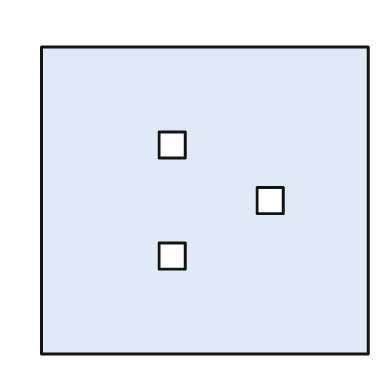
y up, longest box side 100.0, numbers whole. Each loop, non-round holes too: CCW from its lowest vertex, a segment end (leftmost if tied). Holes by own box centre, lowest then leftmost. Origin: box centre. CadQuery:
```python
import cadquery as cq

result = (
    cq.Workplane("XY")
    .moveTo(-50.0, -47.0)
    .lineTo(50.0, -47.0)
    .lineTo(50.0, 47.0)
    .lineTo(-50.0, 47.0)
    .close()
    .moveTo(-14.0, -21.0)
    .lineTo(-6.0, -21.0)
    .lineTo(-6.0, -13.0)
    .lineTo(-14.0, -13.0)
    .close()
    .moveTo(16.0, -4.0)
    .lineTo(24.0, -4.0)
    .lineTo(24.0, 4.0)
    .lineTo(16.0, 4.0)
    .close()
    .moveTo(-14.0, 13.0)
    .lineTo(-6.0, 13.0)
    .lineTo(-6.0, 21.0)
    .lineTo(-14.0, 21.0)
    .close()
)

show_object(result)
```